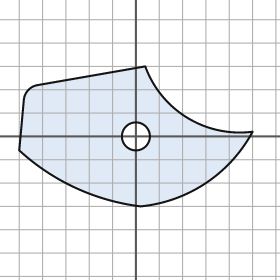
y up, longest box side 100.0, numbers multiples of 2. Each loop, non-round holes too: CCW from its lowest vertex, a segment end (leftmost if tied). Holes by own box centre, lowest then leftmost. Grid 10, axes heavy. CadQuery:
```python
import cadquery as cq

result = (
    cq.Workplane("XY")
    .moveTo(2.0, -30.0)
    .threePointArc((30.0, -20.0), (50.0, 2.0))
    .threePointArc((22.0, 8.0), (4.0, 30.0))
    .lineTo(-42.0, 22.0)
    .threePointArc((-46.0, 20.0), (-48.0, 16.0))
    .lineTo(-50.0, -6.0)
    .threePointArc((-26.0, -22.0), (2.0, -30.0))
    .close()
    .moveTo(0.0, 0.0)
    .circle(6.0)
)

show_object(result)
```